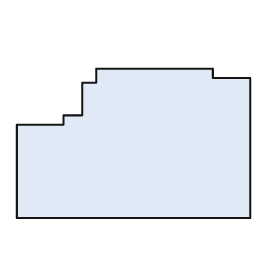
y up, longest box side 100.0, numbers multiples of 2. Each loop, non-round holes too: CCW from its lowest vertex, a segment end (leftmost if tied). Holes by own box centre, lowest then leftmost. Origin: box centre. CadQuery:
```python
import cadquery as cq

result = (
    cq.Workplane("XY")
    .moveTo(-50.0, -32.0)
    .lineTo(50.0, -32.0)
    .lineTo(50.0, 28.0)
    .lineTo(34.0, 28.0)
    .lineTo(34.0, 32.0)
    .lineTo(-16.0, 32.0)
    .lineTo(-16.0, 26.0)
    .lineTo(-22.0, 26.0)
    .lineTo(-22.0, 12.0)
    .lineTo(-30.0, 12.0)
    .lineTo(-30.0, 8.0)
    .lineTo(-50.0, 8.0)
    .close()
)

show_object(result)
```